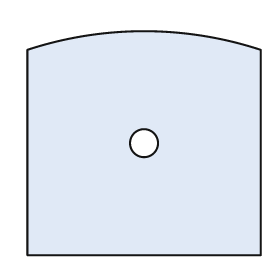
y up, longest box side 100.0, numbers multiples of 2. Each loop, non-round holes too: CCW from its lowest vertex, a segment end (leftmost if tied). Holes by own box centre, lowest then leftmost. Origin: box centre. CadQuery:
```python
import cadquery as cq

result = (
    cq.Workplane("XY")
    .moveTo(-50.0, -48.0)
    .lineTo(50.0, -48.0)
    .lineTo(50.0, 40.0)
    .threePointArc((0.0, 48.0), (-50.0, 40.0))
    .close()
    .moveTo(0.0, 0.0)
    .circle(6.0)
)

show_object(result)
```